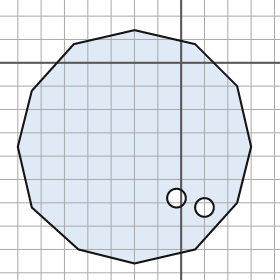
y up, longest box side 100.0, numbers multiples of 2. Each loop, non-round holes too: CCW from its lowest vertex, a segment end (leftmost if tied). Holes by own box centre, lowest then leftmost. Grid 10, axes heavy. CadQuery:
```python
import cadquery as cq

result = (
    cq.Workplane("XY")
    .moveTo(-20.0, -86.0)
    .lineTo(6.0, -80.0)
    .lineTo(24.0, -60.0)
    .lineTo(30.0, -36.0)
    .lineTo(24.0, -10.0)
    .lineTo(6.0, 8.0)
    .lineTo(-20.0, 14.0)
    .lineTo(-46.0, 8.0)
    .lineTo(-64.0, -12.0)
    .lineTo(-70.0, -36.0)
    .lineTo(-64.0, -62.0)
    .lineTo(-44.0, -80.0)
    .close()
    .moveTo(10.0, -62.0)
    .circle(4.0)
    .moveTo(-2.0, -58.0)
    .circle(4.0)
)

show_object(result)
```